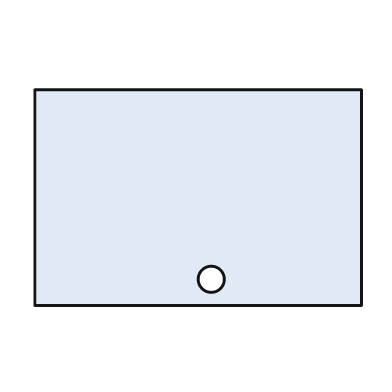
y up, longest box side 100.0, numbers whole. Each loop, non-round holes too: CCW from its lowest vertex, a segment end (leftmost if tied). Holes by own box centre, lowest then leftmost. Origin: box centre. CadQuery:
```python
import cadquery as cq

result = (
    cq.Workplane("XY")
    .moveTo(-50.0, -33.0)
    .lineTo(50.0, -33.0)
    .lineTo(50.0, 33.0)
    .lineTo(-50.0, 33.0)
    .close()
    .moveTo(4.0, -25.0)
    .circle(4.0)
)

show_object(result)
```